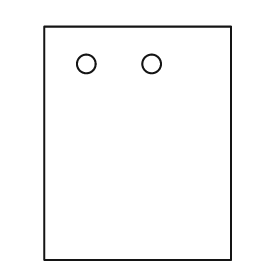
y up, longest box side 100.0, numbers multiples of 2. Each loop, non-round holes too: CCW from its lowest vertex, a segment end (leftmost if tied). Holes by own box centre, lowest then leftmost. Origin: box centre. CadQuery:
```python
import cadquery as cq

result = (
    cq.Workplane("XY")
    .moveTo(-40.0, -50.0)
    .lineTo(40.0, -50.0)
    .lineTo(40.0, 50.0)
    .lineTo(-40.0, 50.0)
    .close()
    .moveTo(-22.0, 34.0)
    .circle(4.0)
    .moveTo(6.0, 34.0)
    .circle(4.0)
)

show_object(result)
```